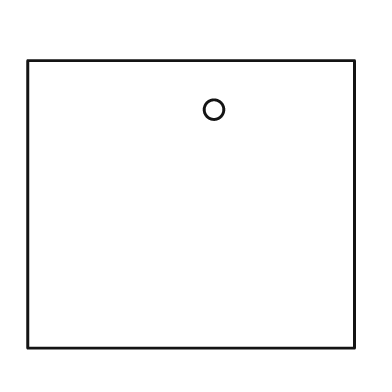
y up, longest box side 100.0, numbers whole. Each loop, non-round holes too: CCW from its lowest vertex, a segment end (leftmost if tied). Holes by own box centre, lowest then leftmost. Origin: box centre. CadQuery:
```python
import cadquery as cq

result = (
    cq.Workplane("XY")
    .moveTo(-50.0, -44.0)
    .lineTo(50.0, -44.0)
    .lineTo(50.0, 44.0)
    .lineTo(-50.0, 44.0)
    .close()
    .moveTo(7.0, 29.0)
    .circle(3.0)
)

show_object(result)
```